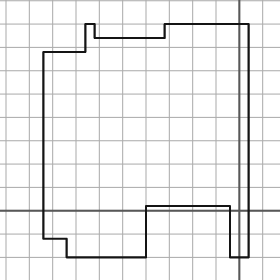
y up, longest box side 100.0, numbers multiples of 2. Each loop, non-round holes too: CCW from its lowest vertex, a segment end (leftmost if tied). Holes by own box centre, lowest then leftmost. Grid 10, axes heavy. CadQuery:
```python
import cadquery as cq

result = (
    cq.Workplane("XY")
    .moveTo(-74.0, -20.0)
    .lineTo(-40.0, -20.0)
    .lineTo(-40.0, 2.0)
    .lineTo(-4.0, 2.0)
    .lineTo(-4.0, -20.0)
    .lineTo(4.0, -20.0)
    .lineTo(4.0, 80.0)
    .lineTo(-32.0, 80.0)
    .lineTo(-32.0, 74.0)
    .lineTo(-62.0, 74.0)
    .lineTo(-62.0, 80.0)
    .lineTo(-66.0, 80.0)
    .lineTo(-66.0, 68.0)
    .lineTo(-84.0, 68.0)
    .lineTo(-84.0, -12.0)
    .lineTo(-74.0, -12.0)
    .close()
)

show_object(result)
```